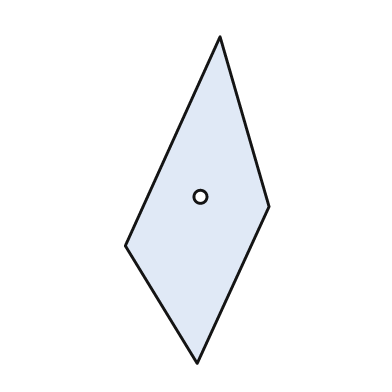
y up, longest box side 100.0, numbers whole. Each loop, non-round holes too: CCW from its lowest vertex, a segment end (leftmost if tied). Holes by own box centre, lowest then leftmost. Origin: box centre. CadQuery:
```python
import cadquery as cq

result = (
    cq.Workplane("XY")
    .moveTo(0.0, -50.0)
    .lineTo(22.0, -2.0)
    .lineTo(7.0, 50.0)
    .lineTo(-22.0, -14.0)
    .close()
    .moveTo(1.0, 1.0)
    .circle(2.0)
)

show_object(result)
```